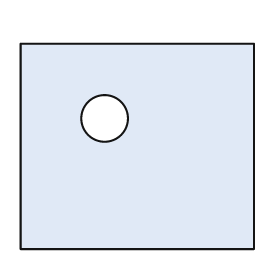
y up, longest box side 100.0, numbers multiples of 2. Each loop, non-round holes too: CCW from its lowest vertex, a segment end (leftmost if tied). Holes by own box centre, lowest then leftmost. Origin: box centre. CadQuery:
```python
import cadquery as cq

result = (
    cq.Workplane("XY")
    .moveTo(-50.0, -44.0)
    .lineTo(50.0, -44.0)
    .lineTo(50.0, 44.0)
    .lineTo(-50.0, 44.0)
    .close()
    .moveTo(-14.0, 12.0)
    .circle(10.0)
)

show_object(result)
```